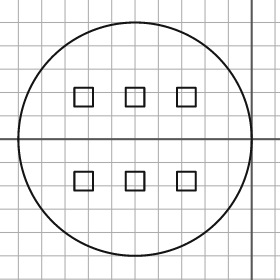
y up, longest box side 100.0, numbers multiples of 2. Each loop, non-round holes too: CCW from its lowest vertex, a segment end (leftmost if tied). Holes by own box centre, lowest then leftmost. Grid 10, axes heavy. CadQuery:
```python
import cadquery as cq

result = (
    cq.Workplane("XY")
    .moveTo(-50.0, 0.0)
    .circle(50.0)
    .moveTo(-76.0, -22.0)
    .lineTo(-68.0, -22.0)
    .lineTo(-68.0, -14.0)
    .lineTo(-76.0, -14.0)
    .close()
    .moveTo(-54.0, -22.0)
    .lineTo(-46.0, -22.0)
    .lineTo(-46.0, -14.0)
    .lineTo(-54.0, -14.0)
    .close()
    .moveTo(-32.0, -22.0)
    .lineTo(-24.0, -22.0)
    .lineTo(-24.0, -14.0)
    .lineTo(-32.0, -14.0)
    .close()
    .moveTo(-76.0, 14.0)
    .lineTo(-68.0, 14.0)
    .lineTo(-68.0, 22.0)
    .lineTo(-76.0, 22.0)
    .close()
    .moveTo(-54.0, 14.0)
    .lineTo(-46.0, 14.0)
    .lineTo(-46.0, 22.0)
    .lineTo(-54.0, 22.0)
    .close()
    .moveTo(-32.0, 14.0)
    .lineTo(-24.0, 14.0)
    .lineTo(-24.0, 22.0)
    .lineTo(-32.0, 22.0)
    .close()
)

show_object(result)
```